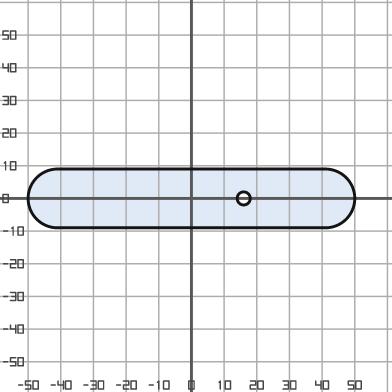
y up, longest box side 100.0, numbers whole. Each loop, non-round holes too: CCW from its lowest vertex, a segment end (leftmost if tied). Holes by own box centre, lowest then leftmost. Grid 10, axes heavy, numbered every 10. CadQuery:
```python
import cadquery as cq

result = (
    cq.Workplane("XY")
    .moveTo(-41.0, -9.0)
    .lineTo(41.0, -9.0)
    .threePointArc((50.0, 0.0), (41.0, 9.0))
    .lineTo(-41.0, 9.0)
    .threePointArc((-50.0, 0.0), (-41.0, -9.0))
    .close()
    .moveTo(16.0, 0.0)
    .circle(2.0)
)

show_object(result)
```